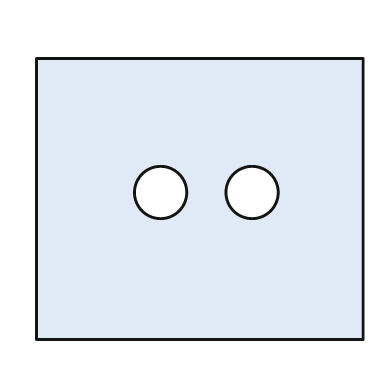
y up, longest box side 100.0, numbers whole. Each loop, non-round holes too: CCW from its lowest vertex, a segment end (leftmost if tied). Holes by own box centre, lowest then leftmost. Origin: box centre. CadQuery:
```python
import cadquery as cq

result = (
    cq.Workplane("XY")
    .moveTo(-50.0, -43.0)
    .lineTo(50.0, -43.0)
    .lineTo(50.0, 43.0)
    .lineTo(-50.0, 43.0)
    .close()
    .moveTo(-12.0, 2.0)
    .circle(8.0)
    .moveTo(16.0, 2.0)
    .circle(8.0)
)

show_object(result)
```